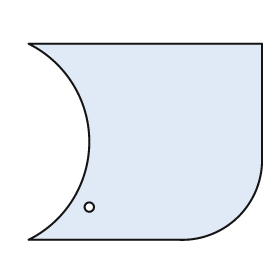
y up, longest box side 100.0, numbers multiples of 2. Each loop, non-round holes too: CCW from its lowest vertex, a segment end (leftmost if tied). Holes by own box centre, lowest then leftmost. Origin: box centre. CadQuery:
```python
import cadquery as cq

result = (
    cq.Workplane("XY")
    .moveTo(-50.0, -42.0)
    .lineTo(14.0, -42.0)
    .threePointArc((40.0, -32.0), (50.0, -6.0))
    .lineTo(50.0, 42.0)
    .lineTo(-50.0, 42.0)
    .threePointArc((-24.0, 0.0), (-50.0, -42.0))
    .close()
    .moveTo(-24.0, -28.0)
    .circle(2.0)
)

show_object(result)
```